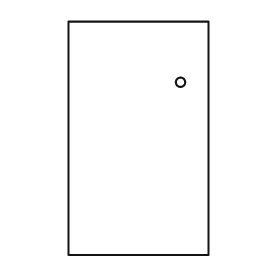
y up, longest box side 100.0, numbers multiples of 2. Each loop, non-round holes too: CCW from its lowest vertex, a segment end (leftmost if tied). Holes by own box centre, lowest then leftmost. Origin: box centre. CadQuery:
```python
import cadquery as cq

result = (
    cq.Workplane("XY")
    .moveTo(-30.0, -50.0)
    .lineTo(30.0, -50.0)
    .lineTo(30.0, 50.0)
    .lineTo(-30.0, 50.0)
    .close()
    .moveTo(18.0, 24.0)
    .circle(2.0)
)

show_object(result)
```